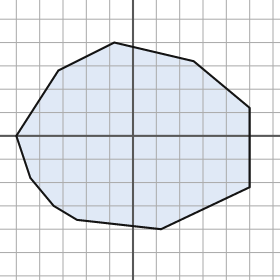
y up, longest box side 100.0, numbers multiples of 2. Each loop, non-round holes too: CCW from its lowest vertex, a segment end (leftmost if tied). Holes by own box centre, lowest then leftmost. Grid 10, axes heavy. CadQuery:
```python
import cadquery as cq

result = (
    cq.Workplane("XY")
    .moveTo(12.0, -40.0)
    .lineTo(50.0, -22.0)
    .lineTo(50.0, 12.0)
    .lineTo(26.0, 32.0)
    .lineTo(-8.0, 40.0)
    .lineTo(-32.0, 28.0)
    .lineTo(-50.0, 0.0)
    .lineTo(-44.0, -18.0)
    .lineTo(-34.0, -30.0)
    .lineTo(-24.0, -36.0)
    .close()
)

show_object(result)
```